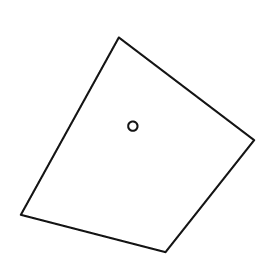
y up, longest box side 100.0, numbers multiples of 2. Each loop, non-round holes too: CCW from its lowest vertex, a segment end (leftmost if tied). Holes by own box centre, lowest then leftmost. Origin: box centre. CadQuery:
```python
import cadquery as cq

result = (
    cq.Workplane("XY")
    .moveTo(12.0, -46.0)
    .lineTo(50.0, 2.0)
    .lineTo(-8.0, 46.0)
    .lineTo(-50.0, -30.0)
    .close()
    .moveTo(-2.0, 8.0)
    .circle(2.0)
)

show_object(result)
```